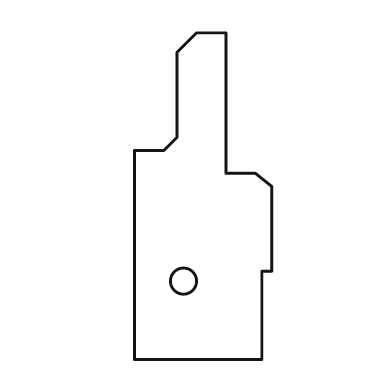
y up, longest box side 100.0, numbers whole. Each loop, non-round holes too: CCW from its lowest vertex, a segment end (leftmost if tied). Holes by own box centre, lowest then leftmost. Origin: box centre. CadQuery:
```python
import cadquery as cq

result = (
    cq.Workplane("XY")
    .moveTo(-21.0, -50.0)
    .lineTo(18.0, -50.0)
    .lineTo(18.0, -23.0)
    .lineTo(21.0, -23.0)
    .lineTo(21.0, 3.0)
    .lineTo(16.0, 7.0)
    .lineTo(7.0, 7.0)
    .lineTo(7.0, 50.0)
    .lineTo(-2.0, 50.0)
    .lineTo(-8.0, 44.0)
    .lineTo(-8.0, 18.0)
    .lineTo(-12.0, 14.0)
    .lineTo(-21.0, 14.0)
    .close()
    .moveTo(-6.0, -26.0)
    .circle(4.0)
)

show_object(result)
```